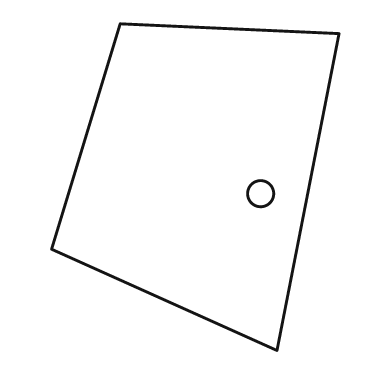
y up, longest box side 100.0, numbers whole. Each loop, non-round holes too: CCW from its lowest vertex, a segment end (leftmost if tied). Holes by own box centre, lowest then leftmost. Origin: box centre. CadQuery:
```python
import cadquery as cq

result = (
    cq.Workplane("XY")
    .moveTo(25.0, -50.0)
    .lineTo(44.0, 47.0)
    .lineTo(-23.0, 50.0)
    .lineTo(-44.0, -19.0)
    .close()
    .moveTo(20.0, -2.0)
    .circle(4.0)
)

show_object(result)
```